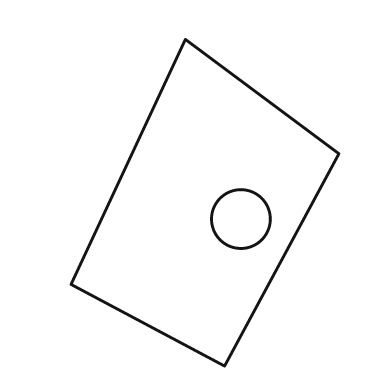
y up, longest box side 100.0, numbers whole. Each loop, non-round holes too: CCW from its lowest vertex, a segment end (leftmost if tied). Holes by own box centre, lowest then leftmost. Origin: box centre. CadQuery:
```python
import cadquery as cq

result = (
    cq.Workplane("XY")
    .moveTo(6.0, -50.0)
    .lineTo(41.0, 15.0)
    .lineTo(-6.0, 50.0)
    .lineTo(-41.0, -25.0)
    .close()
    .moveTo(11.0, -5.0)
    .circle(9.0)
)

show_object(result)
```